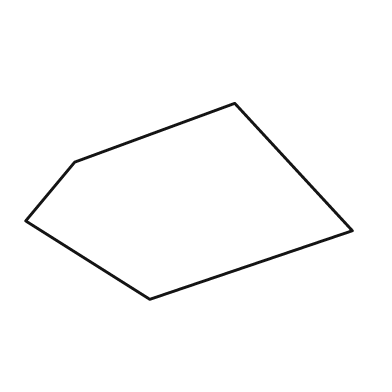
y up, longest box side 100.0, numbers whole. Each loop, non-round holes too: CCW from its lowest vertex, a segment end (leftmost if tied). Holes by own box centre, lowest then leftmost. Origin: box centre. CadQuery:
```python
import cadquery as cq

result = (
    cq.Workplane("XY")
    .moveTo(-12.0, -30.0)
    .lineTo(50.0, -9.0)
    .lineTo(14.0, 30.0)
    .lineTo(-35.0, 12.0)
    .lineTo(-50.0, -6.0)
    .close()
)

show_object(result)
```